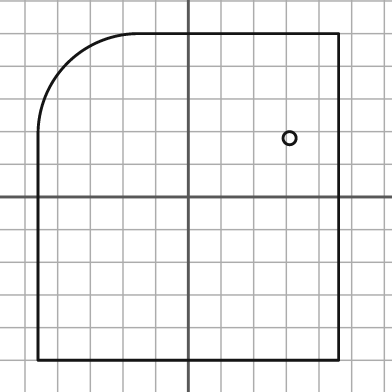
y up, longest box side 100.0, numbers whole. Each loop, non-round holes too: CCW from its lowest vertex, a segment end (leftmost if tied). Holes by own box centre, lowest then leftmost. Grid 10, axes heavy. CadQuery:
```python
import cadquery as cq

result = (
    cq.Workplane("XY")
    .moveTo(-46.0, -50.0)
    .lineTo(46.0, -50.0)
    .lineTo(46.0, 50.0)
    .lineTo(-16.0, 50.0)
    .threePointArc((-37.0, 41.0), (-46.0, 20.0))
    .close()
    .moveTo(31.0, 18.0)
    .circle(2.0)
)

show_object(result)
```